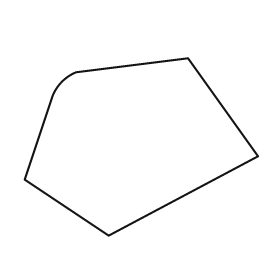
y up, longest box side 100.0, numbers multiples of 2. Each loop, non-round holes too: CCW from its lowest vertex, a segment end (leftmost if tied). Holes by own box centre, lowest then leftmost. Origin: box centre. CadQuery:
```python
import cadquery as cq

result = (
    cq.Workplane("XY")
    .moveTo(-14.0, -38.0)
    .lineTo(50.0, -4.0)
    .lineTo(20.0, 38.0)
    .lineTo(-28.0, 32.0)
    .threePointArc((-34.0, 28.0), (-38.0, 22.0))
    .lineTo(-50.0, -14.0)
    .close()
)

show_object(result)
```